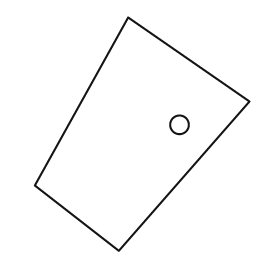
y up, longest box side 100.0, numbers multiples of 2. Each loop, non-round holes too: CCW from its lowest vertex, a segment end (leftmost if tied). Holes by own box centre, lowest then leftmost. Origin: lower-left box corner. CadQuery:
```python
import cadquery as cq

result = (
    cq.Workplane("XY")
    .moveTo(36.0, 0.0)
    .lineTo(92.0, 64.0)
    .lineTo(40.0, 100.0)
    .lineTo(0.0, 28.0)
    .close()
    .moveTo(62.0, 54.0)
    .circle(4.0)
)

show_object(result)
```